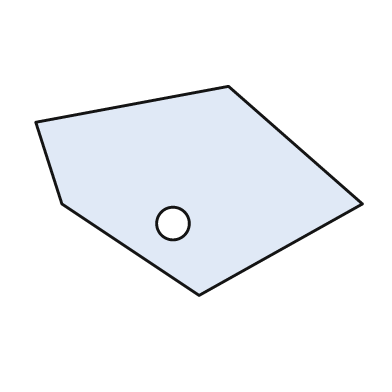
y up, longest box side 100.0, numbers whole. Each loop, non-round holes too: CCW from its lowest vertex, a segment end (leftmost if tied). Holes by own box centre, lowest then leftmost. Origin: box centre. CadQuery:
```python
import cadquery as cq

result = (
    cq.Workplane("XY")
    .moveTo(0.0, -32.0)
    .lineTo(50.0, -4.0)
    .lineTo(9.0, 32.0)
    .lineTo(-50.0, 21.0)
    .lineTo(-42.0, -4.0)
    .close()
    .moveTo(-8.0, -10.0)
    .circle(5.0)
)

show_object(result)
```